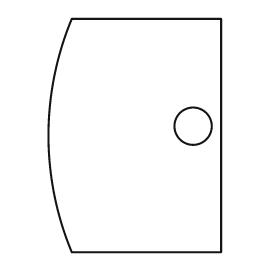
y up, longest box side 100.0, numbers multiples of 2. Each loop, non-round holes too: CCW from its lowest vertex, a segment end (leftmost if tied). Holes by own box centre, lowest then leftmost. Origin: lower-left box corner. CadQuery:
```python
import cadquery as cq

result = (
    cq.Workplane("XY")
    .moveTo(10.0, 0.0)
    .lineTo(74.0, 0.0)
    .lineTo(74.0, 100.0)
    .lineTo(10.0, 100.0)
    .threePointArc((0.0, 50.0), (10.0, 0.0))
    .close()
    .moveTo(62.0, 54.0)
    .circle(8.0)
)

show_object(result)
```